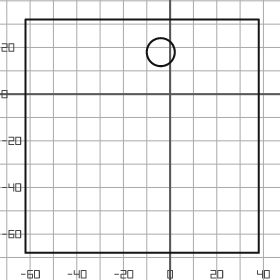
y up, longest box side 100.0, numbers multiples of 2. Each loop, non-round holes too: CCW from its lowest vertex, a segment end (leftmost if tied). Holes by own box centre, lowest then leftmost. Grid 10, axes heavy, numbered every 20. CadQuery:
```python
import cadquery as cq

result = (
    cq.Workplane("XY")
    .moveTo(-62.0, -68.0)
    .lineTo(38.0, -68.0)
    .lineTo(38.0, 32.0)
    .lineTo(-62.0, 32.0)
    .close()
    .moveTo(-4.0, 18.0)
    .circle(6.0)
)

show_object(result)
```